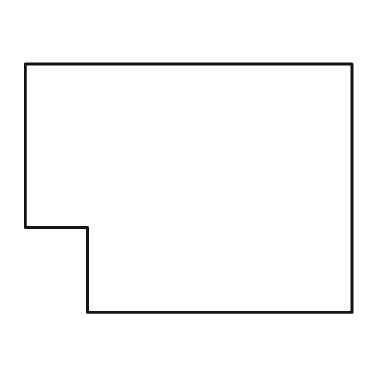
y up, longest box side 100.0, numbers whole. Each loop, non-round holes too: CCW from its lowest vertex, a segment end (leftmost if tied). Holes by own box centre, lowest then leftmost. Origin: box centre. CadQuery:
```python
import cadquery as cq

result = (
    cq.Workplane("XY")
    .moveTo(-31.0, -38.0)
    .lineTo(50.0, -38.0)
    .lineTo(50.0, 38.0)
    .lineTo(-50.0, 38.0)
    .lineTo(-50.0, -12.0)
    .lineTo(-31.0, -12.0)
    .close()
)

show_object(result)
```